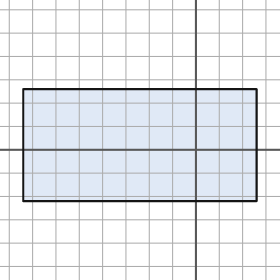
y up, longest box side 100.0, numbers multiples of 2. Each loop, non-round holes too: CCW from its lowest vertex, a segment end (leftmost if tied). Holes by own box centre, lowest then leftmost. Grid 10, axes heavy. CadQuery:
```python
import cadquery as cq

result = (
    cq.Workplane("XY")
    .moveTo(-74.0, -22.0)
    .lineTo(26.0, -22.0)
    .lineTo(26.0, 26.0)
    .lineTo(-74.0, 26.0)
    .close()
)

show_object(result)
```